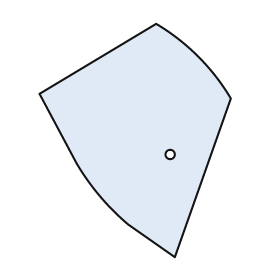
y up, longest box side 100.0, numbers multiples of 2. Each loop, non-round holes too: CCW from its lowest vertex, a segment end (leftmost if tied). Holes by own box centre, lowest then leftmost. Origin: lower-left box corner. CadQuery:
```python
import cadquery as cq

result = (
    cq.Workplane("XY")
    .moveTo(58.0, 0.0)
    .lineTo(82.0, 68.0)
    .threePointArc((68.0, 86.0), (50.0, 100.0))
    .lineTo(0.0, 70.0)
    .lineTo(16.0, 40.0)
    .threePointArc((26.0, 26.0), (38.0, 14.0))
    .close()
    .moveTo(56.0, 44.0)
    .circle(2.0)
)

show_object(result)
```